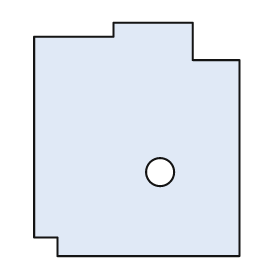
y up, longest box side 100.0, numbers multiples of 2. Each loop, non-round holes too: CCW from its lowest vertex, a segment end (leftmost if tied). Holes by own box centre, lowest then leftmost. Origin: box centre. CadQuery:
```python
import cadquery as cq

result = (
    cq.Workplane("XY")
    .moveTo(-34.0, -50.0)
    .lineTo(44.0, -50.0)
    .lineTo(44.0, 34.0)
    .lineTo(24.0, 34.0)
    .lineTo(24.0, 50.0)
    .lineTo(-10.0, 50.0)
    .lineTo(-10.0, 44.0)
    .lineTo(-44.0, 44.0)
    .lineTo(-44.0, -42.0)
    .lineTo(-34.0, -42.0)
    .close()
    .moveTo(10.0, -14.0)
    .circle(6.0)
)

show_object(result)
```